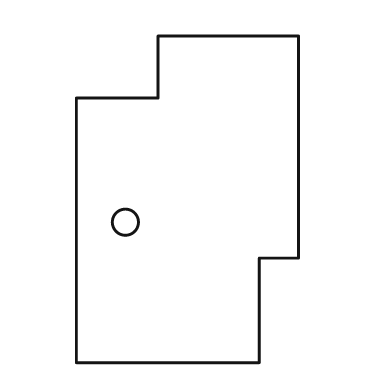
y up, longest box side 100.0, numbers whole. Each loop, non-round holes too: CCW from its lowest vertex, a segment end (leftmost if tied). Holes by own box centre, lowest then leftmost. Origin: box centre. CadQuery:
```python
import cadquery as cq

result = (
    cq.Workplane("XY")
    .moveTo(-34.0, -50.0)
    .lineTo(22.0, -50.0)
    .lineTo(22.0, -18.0)
    .lineTo(34.0, -18.0)
    .lineTo(34.0, 50.0)
    .lineTo(-9.0, 50.0)
    .lineTo(-9.0, 31.0)
    .lineTo(-34.0, 31.0)
    .close()
    .moveTo(-19.0, -7.0)
    .circle(4.0)
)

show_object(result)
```